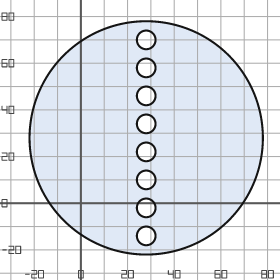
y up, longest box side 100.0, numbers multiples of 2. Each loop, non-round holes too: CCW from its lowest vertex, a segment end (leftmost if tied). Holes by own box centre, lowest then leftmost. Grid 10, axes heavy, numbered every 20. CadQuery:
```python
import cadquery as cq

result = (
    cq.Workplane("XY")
    .moveTo(28.0, 28.0)
    .circle(50.0)
    .moveTo(28.0, -14.0)
    .circle(4.0)
    .moveTo(28.0, -2.0)
    .circle(4.0)
    .moveTo(28.0, 10.0)
    .circle(4.0)
    .moveTo(28.0, 22.0)
    .circle(4.0)
    .moveTo(28.0, 34.0)
    .circle(4.0)
    .moveTo(28.0, 46.0)
    .circle(4.0)
    .moveTo(28.0, 58.0)
    .circle(4.0)
    .moveTo(28.0, 70.0)
    .circle(4.0)
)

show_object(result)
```